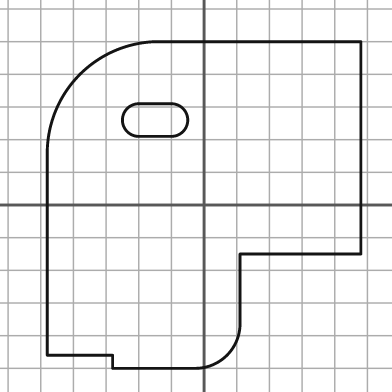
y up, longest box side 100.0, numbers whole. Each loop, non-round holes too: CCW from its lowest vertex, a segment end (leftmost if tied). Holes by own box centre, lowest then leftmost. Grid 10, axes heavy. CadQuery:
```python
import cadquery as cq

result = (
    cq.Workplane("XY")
    .moveTo(-28.0, -50.0)
    .lineTo(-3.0, -50.0)
    .threePointArc((7.0, -46.0), (11.0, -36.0))
    .lineTo(11.0, -15.0)
    .lineTo(48.0, -15.0)
    .lineTo(48.0, 50.0)
    .lineTo(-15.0, 50.0)
    .threePointArc((-38.0, 40.0), (-48.0, 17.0))
    .lineTo(-48.0, -46.0)
    .lineTo(-28.0, -46.0)
    .close()
    .moveTo(-20.0, 21.0)
    .lineTo(-10.0, 21.0)
    .threePointArc((-5.0, 26.0), (-10.0, 31.0))
    .lineTo(-20.0, 31.0)
    .threePointArc((-25.0, 26.0), (-20.0, 21.0))
    .close()
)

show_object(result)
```